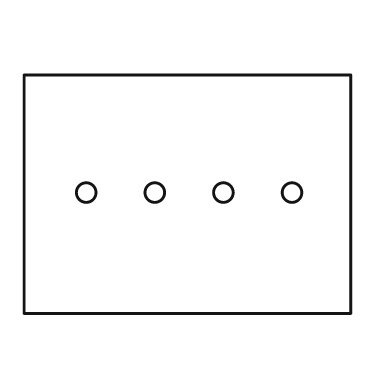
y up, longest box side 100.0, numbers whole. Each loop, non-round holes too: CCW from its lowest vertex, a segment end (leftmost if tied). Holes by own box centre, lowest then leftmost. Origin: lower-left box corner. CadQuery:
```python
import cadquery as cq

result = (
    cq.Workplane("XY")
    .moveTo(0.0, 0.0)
    .lineTo(100.0, 0.0)
    .lineTo(100.0, 73.0)
    .lineTo(0.0, 73.0)
    .close()
    .moveTo(19.0, 37.0)
    .circle(3.0)
    .moveTo(40.0, 37.0)
    .circle(3.0)
    .moveTo(61.0, 37.0)
    .circle(3.0)
    .moveTo(82.0, 37.0)
    .circle(3.0)
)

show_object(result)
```